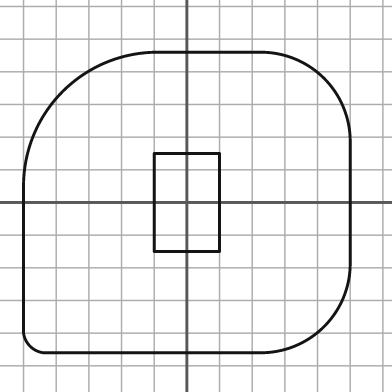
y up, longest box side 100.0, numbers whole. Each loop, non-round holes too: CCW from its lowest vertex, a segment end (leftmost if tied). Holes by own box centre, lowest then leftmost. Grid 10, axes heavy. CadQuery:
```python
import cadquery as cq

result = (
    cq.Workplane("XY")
    .moveTo(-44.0, -46.0)
    .lineTo(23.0, -46.0)
    .threePointArc((42.0, -38.0), (50.0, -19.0))
    .lineTo(50.0, 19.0)
    .threePointArc((42.0, 38.0), (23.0, 46.0))
    .lineTo(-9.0, 46.0)
    .threePointArc((-38.0, 34.0), (-50.0, 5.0))
    .lineTo(-50.0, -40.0)
    .threePointArc((-48.0, -44.0), (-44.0, -46.0))
    .close()
    .moveTo(-10.0, -15.0)
    .lineTo(10.0, -15.0)
    .lineTo(10.0, 15.0)
    .lineTo(-10.0, 15.0)
    .close()
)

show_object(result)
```